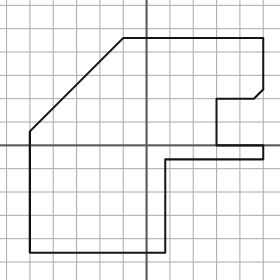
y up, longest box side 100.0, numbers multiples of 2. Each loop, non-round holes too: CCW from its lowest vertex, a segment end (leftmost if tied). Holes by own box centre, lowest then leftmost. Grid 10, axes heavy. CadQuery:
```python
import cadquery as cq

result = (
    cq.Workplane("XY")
    .moveTo(-50.0, -46.0)
    .lineTo(8.0, -46.0)
    .lineTo(8.0, -6.0)
    .lineTo(50.0, -6.0)
    .lineTo(50.0, 0.0)
    .lineTo(30.0, 0.0)
    .lineTo(30.0, 20.0)
    .lineTo(46.0, 20.0)
    .lineTo(50.0, 24.0)
    .lineTo(50.0, 46.0)
    .lineTo(-10.0, 46.0)
    .lineTo(-50.0, 6.0)
    .close()
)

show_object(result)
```